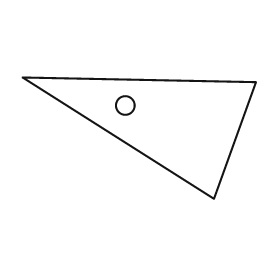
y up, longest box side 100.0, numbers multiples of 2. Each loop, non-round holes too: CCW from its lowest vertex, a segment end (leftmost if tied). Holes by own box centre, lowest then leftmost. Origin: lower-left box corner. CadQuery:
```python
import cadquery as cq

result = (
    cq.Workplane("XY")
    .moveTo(82.0, 0.0)
    .lineTo(100.0, 50.0)
    .lineTo(0.0, 52.0)
    .close()
    .moveTo(44.0, 40.0)
    .circle(4.0)
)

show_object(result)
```